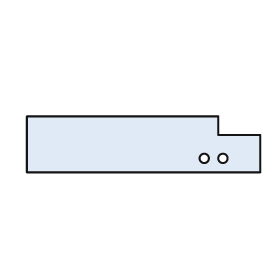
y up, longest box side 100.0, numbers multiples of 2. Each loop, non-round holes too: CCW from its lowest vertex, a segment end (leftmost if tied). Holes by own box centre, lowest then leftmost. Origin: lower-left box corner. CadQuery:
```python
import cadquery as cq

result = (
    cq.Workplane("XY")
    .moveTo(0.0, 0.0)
    .lineTo(100.0, 0.0)
    .lineTo(100.0, 16.0)
    .lineTo(82.0, 16.0)
    .lineTo(82.0, 24.0)
    .lineTo(0.0, 24.0)
    .close()
    .moveTo(76.0, 6.0)
    .circle(2.0)
    .moveTo(84.0, 6.0)
    .circle(2.0)
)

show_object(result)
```